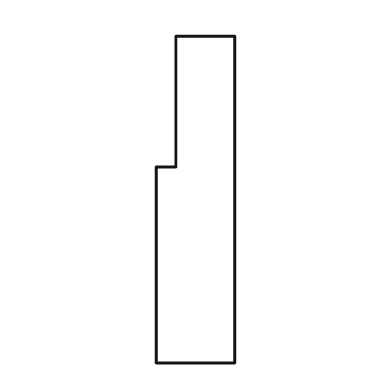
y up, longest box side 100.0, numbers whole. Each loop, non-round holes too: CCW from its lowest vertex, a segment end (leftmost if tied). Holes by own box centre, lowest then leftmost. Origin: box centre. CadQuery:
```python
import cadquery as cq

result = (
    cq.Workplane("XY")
    .moveTo(-12.0, -50.0)
    .lineTo(12.0, -50.0)
    .lineTo(12.0, 50.0)
    .lineTo(-6.0, 50.0)
    .lineTo(-6.0, 10.0)
    .lineTo(-12.0, 10.0)
    .close()
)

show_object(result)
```